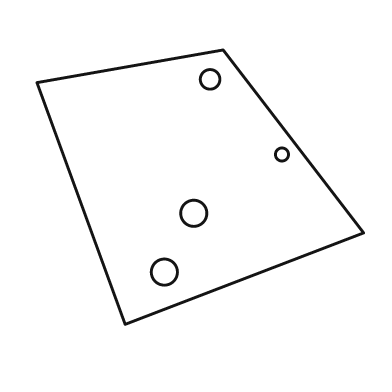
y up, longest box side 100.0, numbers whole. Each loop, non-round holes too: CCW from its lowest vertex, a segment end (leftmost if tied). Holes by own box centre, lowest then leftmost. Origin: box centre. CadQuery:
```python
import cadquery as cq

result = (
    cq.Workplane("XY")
    .moveTo(-23.0, -42.0)
    .lineTo(50.0, -14.0)
    .lineTo(7.0, 42.0)
    .lineTo(-50.0, 32.0)
    .close()
    .moveTo(-11.0, -26.0)
    .circle(4.0)
    .moveTo(-2.0, -8.0)
    .circle(4.0)
    .moveTo(25.0, 10.0)
    .circle(2.0)
    .moveTo(3.0, 33.0)
    .circle(3.0)
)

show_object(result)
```